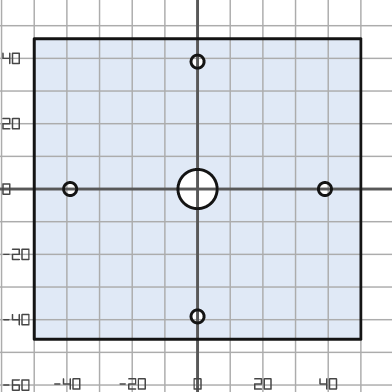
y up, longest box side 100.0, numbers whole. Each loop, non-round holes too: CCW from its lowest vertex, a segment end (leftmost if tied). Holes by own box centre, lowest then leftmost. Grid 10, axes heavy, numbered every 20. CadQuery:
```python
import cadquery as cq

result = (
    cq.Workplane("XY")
    .moveTo(-50.0, -46.0)
    .lineTo(50.0, -46.0)
    .lineTo(50.0, 46.0)
    .lineTo(-50.0, 46.0)
    .close()
    .moveTo(0.0, -39.0)
    .circle(2.0)
    .moveTo(-39.0, 0.0)
    .circle(2.0)
    .moveTo(0.0, 0.0)
    .circle(6.0)
    .moveTo(39.0, 0.0)
    .circle(2.0)
    .moveTo(0.0, 39.0)
    .circle(2.0)
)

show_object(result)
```